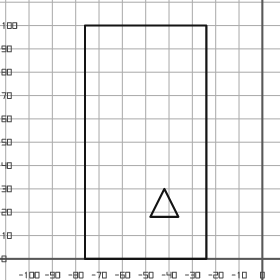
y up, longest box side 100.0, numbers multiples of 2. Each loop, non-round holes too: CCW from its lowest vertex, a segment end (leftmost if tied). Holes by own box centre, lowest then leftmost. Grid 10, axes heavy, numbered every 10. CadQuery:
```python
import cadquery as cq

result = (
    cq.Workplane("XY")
    .moveTo(-76.0, 0.0)
    .lineTo(-24.0, 0.0)
    .lineTo(-24.0, 100.0)
    .lineTo(-76.0, 100.0)
    .close()
    .moveTo(-48.0, 18.0)
    .lineTo(-36.0, 18.0)
    .lineTo(-42.0, 30.0)
    .close()
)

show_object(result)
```